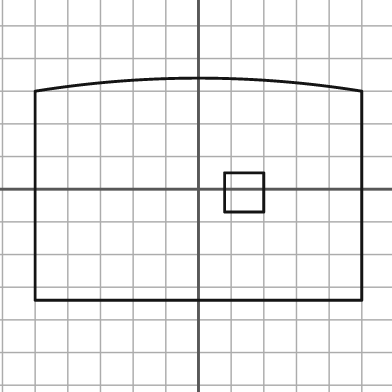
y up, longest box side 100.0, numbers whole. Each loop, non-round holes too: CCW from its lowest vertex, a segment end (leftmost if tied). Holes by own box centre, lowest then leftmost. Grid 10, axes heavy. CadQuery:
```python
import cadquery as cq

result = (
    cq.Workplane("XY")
    .moveTo(-50.0, -34.0)
    .lineTo(50.0, -34.0)
    .lineTo(50.0, 30.0)
    .threePointArc((0.0, 34.0), (-50.0, 30.0))
    .close()
    .moveTo(8.0, -7.0)
    .lineTo(20.0, -7.0)
    .lineTo(20.0, 5.0)
    .lineTo(8.0, 5.0)
    .close()
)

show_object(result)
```